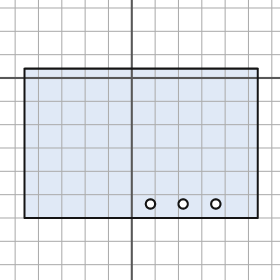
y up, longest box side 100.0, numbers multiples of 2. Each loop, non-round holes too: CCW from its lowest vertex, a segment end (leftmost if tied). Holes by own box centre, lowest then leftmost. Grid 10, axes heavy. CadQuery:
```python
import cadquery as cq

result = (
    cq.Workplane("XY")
    .moveTo(-46.0, -60.0)
    .lineTo(54.0, -60.0)
    .lineTo(54.0, 4.0)
    .lineTo(-46.0, 4.0)
    .close()
    .moveTo(8.0, -54.0)
    .circle(2.0)
    .moveTo(22.0, -54.0)
    .circle(2.0)
    .moveTo(36.0, -54.0)
    .circle(2.0)
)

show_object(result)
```